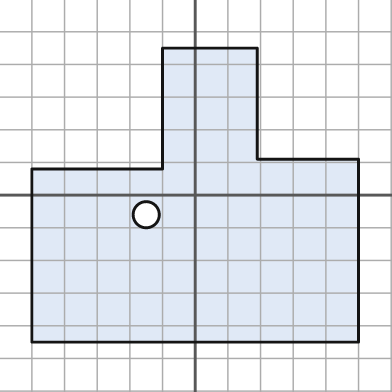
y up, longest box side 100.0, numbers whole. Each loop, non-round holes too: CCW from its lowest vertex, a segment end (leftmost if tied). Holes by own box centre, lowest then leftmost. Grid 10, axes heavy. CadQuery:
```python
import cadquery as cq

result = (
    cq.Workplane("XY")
    .moveTo(-50.0, -45.0)
    .lineTo(50.0, -45.0)
    .lineTo(50.0, 11.0)
    .lineTo(19.0, 11.0)
    .lineTo(19.0, 45.0)
    .lineTo(-10.0, 45.0)
    .lineTo(-10.0, 8.0)
    .lineTo(-50.0, 8.0)
    .close()
    .moveTo(-15.0, -6.0)
    .circle(4.0)
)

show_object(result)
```